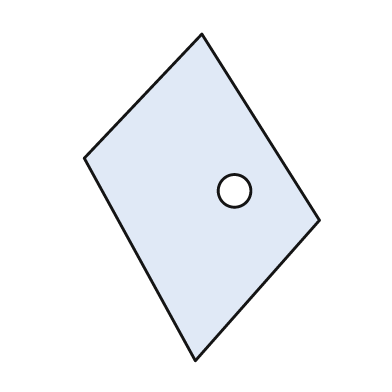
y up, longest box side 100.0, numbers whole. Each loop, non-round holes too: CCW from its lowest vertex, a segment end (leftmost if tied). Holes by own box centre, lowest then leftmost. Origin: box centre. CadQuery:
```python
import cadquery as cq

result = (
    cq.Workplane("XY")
    .moveTo(-2.0, -50.0)
    .lineTo(36.0, -7.0)
    .lineTo(0.0, 50.0)
    .lineTo(-36.0, 12.0)
    .close()
    .moveTo(10.0, 2.0)
    .circle(5.0)
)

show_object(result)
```